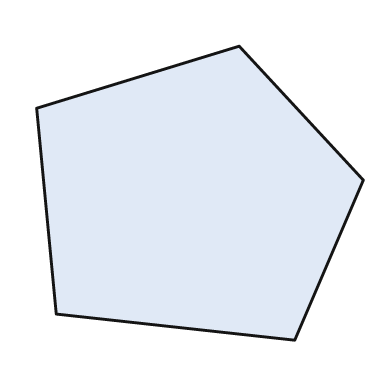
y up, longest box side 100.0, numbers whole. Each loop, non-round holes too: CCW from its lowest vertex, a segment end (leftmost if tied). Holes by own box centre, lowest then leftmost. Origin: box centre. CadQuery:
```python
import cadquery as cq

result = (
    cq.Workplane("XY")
    .moveTo(29.0, -45.0)
    .lineTo(50.0, 4.0)
    .lineTo(12.0, 45.0)
    .lineTo(-50.0, 26.0)
    .lineTo(-44.0, -37.0)
    .close()
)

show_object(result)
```